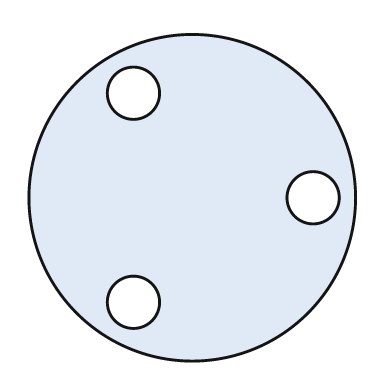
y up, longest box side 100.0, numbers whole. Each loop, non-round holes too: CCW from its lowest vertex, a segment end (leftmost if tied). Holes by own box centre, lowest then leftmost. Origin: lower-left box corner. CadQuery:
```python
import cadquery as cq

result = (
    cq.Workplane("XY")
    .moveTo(50.0, 50.0)
    .circle(50.0)
    .moveTo(32.0, 18.0)
    .circle(8.0)
    .moveTo(87.0, 50.0)
    .circle(8.0)
    .moveTo(32.0, 82.0)
    .circle(8.0)
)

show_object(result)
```